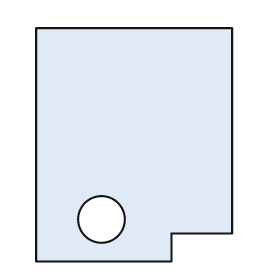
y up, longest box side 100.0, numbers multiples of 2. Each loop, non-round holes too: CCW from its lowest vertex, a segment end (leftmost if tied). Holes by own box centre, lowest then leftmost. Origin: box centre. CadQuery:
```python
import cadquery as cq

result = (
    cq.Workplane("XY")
    .moveTo(-42.0, -50.0)
    .lineTo(16.0, -50.0)
    .lineTo(16.0, -38.0)
    .lineTo(42.0, -38.0)
    .lineTo(42.0, 50.0)
    .lineTo(-42.0, 50.0)
    .close()
    .moveTo(-14.0, -32.0)
    .circle(10.0)
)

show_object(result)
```